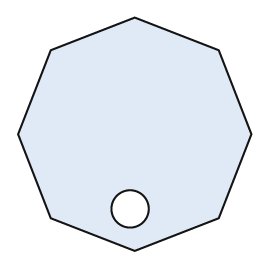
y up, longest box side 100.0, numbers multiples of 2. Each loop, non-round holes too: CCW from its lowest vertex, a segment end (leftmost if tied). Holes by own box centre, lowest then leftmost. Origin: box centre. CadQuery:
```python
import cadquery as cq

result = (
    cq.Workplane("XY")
    .moveTo(0.0, -50.0)
    .lineTo(36.0, -36.0)
    .lineTo(50.0, 0.0)
    .lineTo(36.0, 36.0)
    .lineTo(0.0, 50.0)
    .lineTo(-36.0, 36.0)
    .lineTo(-50.0, 0.0)
    .lineTo(-36.0, -36.0)
    .close()
    .moveTo(-2.0, -32.0)
    .circle(8.0)
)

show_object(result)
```